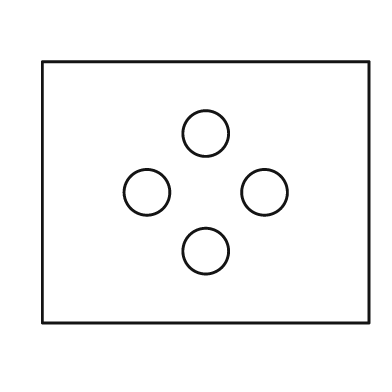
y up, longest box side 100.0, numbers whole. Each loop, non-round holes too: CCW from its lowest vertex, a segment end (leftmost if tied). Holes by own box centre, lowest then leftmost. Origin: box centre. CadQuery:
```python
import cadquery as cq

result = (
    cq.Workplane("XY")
    .moveTo(-50.0, -40.0)
    .lineTo(50.0, -40.0)
    .lineTo(50.0, 40.0)
    .lineTo(-50.0, 40.0)
    .close()
    .moveTo(0.0, -18.0)
    .circle(7.0)
    .moveTo(-18.0, 0.0)
    .circle(7.0)
    .moveTo(18.0, 0.0)
    .circle(7.0)
    .moveTo(0.0, 18.0)
    .circle(7.0)
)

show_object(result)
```